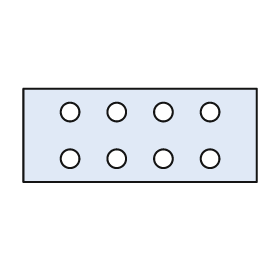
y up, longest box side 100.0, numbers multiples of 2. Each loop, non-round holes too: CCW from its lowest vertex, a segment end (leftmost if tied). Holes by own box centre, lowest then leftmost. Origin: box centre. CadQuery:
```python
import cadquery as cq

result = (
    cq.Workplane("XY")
    .moveTo(-50.0, -20.0)
    .lineTo(50.0, -20.0)
    .lineTo(50.0, 20.0)
    .lineTo(-50.0, 20.0)
    .close()
    .moveTo(-30.0, -10.0)
    .circle(4.0)
    .moveTo(-10.0, -10.0)
    .circle(4.0)
    .moveTo(10.0, -10.0)
    .circle(4.0)
    .moveTo(30.0, -10.0)
    .circle(4.0)
    .moveTo(-30.0, 10.0)
    .circle(4.0)
    .moveTo(-10.0, 10.0)
    .circle(4.0)
    .moveTo(10.0, 10.0)
    .circle(4.0)
    .moveTo(30.0, 10.0)
    .circle(4.0)
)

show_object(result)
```